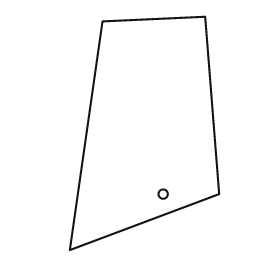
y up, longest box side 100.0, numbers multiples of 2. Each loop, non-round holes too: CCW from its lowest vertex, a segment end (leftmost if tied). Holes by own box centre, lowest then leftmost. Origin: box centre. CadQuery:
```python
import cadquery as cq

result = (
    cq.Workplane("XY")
    .moveTo(-32.0, -50.0)
    .lineTo(32.0, -26.0)
    .lineTo(26.0, 50.0)
    .lineTo(-18.0, 48.0)
    .close()
    .moveTo(8.0, -26.0)
    .circle(2.0)
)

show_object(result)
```